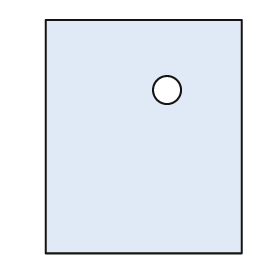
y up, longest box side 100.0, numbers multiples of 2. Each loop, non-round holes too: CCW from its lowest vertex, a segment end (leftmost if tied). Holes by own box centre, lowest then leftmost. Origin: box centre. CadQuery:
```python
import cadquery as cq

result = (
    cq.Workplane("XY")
    .moveTo(-42.0, -50.0)
    .lineTo(42.0, -50.0)
    .lineTo(42.0, 50.0)
    .lineTo(-42.0, 50.0)
    .close()
    .moveTo(10.0, 20.0)
    .circle(6.0)
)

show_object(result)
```